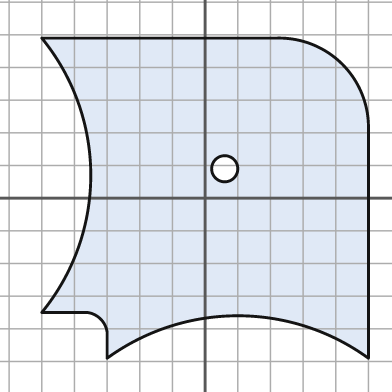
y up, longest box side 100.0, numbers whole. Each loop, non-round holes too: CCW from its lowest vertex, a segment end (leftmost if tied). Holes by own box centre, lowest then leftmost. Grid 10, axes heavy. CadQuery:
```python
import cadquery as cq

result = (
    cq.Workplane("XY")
    .moveTo(-30.0, -49.0)
    .threePointArc((10.0, -36.0), (50.0, -49.0))
    .lineTo(50.0, 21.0)
    .threePointArc((42.0, 41.0), (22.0, 49.0))
    .lineTo(-50.0, 49.0)
    .threePointArc((-35.0, 7.0), (-50.0, -35.0))
    .lineTo(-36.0, -35.0)
    .threePointArc((-32.0, -37.0), (-30.0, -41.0))
    .close()
    .moveTo(6.0, 9.0)
    .circle(4.0)
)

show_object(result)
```